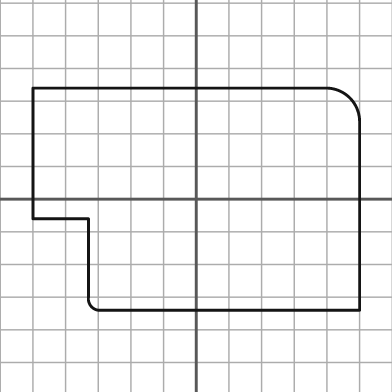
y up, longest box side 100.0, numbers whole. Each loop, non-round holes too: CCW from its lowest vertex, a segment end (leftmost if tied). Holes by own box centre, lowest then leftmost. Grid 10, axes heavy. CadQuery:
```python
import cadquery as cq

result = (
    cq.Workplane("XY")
    .moveTo(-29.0, -34.0)
    .lineTo(50.0, -34.0)
    .lineTo(50.0, 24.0)
    .threePointArc((47.0, 31.0), (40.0, 34.0))
    .lineTo(-50.0, 34.0)
    .lineTo(-50.0, -6.0)
    .lineTo(-33.0, -6.0)
    .lineTo(-33.0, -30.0)
    .threePointArc((-32.0, -33.0), (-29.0, -34.0))
    .close()
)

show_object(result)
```